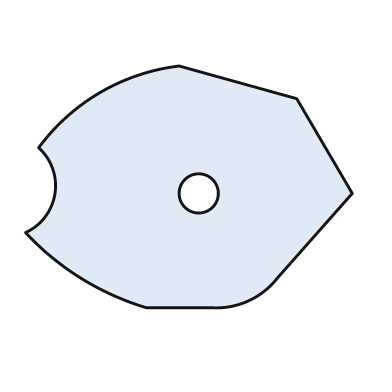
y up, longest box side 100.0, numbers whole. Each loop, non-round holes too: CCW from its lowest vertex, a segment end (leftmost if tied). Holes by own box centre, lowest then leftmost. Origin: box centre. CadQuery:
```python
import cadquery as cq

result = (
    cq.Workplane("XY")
    .moveTo(-13.0, -37.0)
    .lineTo(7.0, -37.0)
    .threePointArc((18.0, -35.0), (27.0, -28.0))
    .lineTo(50.0, -2.0)
    .lineTo(33.0, 27.0)
    .lineTo(-3.0, 37.0)
    .threePointArc((-27.0, 29.0), (-46.0, 12.0))
    .threePointArc((-41.0, -2.0), (-50.0, -14.0))
    .threePointArc((-33.0, -28.0), (-13.0, -37.0))
    .close()
    .moveTo(3.0, -2.0)
    .circle(6.0)
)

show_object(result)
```